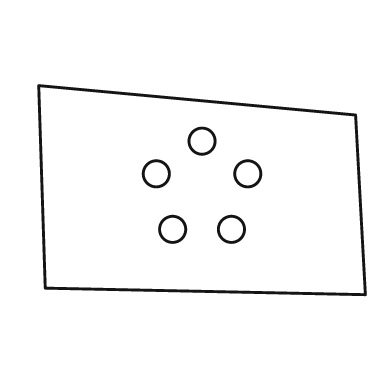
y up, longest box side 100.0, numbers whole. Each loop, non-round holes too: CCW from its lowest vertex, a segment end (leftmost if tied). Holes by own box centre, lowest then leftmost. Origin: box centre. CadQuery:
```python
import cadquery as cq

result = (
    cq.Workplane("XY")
    .moveTo(50.0, -32.0)
    .lineTo(47.0, 23.0)
    .lineTo(-50.0, 32.0)
    .lineTo(-48.0, -30.0)
    .close()
    .moveTo(-9.0, -12.0)
    .circle(4.0)
    .moveTo(9.0, -12.0)
    .circle(4.0)
    .moveTo(-14.0, 5.0)
    .circle(4.0)
    .moveTo(14.0, 5.0)
    .circle(4.0)
    .moveTo(0.0, 15.0)
    .circle(4.0)
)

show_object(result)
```